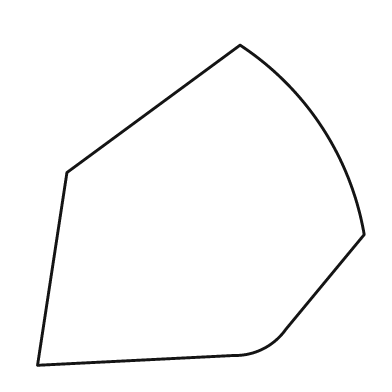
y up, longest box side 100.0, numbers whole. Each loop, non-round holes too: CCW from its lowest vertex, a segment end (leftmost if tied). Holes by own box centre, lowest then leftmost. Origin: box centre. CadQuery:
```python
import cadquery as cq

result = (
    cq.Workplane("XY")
    .moveTo(-50.0, -49.0)
    .lineTo(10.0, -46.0)
    .threePointArc((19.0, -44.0), (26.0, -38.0))
    .lineTo(50.0, -9.0)
    .threePointArc((37.0, 24.0), (12.0, 49.0))
    .lineTo(-41.0, 10.0)
    .close()
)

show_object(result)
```